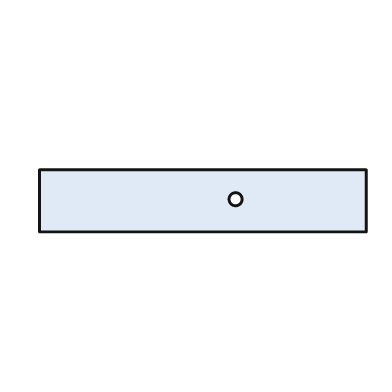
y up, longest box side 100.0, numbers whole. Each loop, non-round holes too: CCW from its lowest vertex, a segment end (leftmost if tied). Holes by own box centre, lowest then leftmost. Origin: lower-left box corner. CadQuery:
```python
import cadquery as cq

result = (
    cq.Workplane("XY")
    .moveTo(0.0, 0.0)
    .lineTo(100.0, 0.0)
    .lineTo(100.0, 19.0)
    .lineTo(0.0, 19.0)
    .close()
    .moveTo(60.0, 10.0)
    .circle(2.0)
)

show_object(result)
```